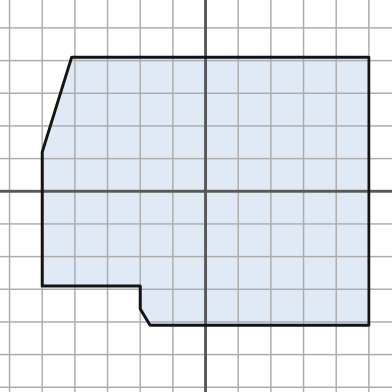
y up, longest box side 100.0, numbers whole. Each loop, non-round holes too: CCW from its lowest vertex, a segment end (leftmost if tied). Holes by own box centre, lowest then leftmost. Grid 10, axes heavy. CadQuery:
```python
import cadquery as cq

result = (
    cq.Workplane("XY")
    .moveTo(-17.0, -41.0)
    .lineTo(50.0, -41.0)
    .lineTo(50.0, 41.0)
    .lineTo(-41.0, 41.0)
    .lineTo(-50.0, 12.0)
    .lineTo(-50.0, -29.0)
    .lineTo(-20.0, -29.0)
    .lineTo(-20.0, -36.0)
    .close()
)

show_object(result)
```